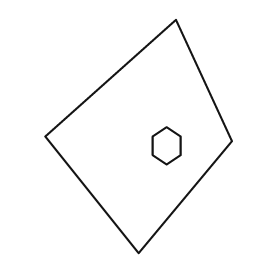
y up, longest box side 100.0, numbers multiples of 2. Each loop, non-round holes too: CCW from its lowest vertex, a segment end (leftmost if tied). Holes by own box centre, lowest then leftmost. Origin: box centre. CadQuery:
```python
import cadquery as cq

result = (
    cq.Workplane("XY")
    .moveTo(0.0, -50.0)
    .lineTo(40.0, -2.0)
    .lineTo(16.0, 50.0)
    .lineTo(-40.0, 0.0)
    .close()
    .moveTo(12.0, -12.0)
    .lineTo(18.0, -8.0)
    .lineTo(18.0, 0.0)
    .lineTo(12.0, 4.0)
    .lineTo(6.0, 0.0)
    .lineTo(6.0, -8.0)
    .close()
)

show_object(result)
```